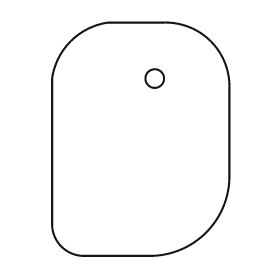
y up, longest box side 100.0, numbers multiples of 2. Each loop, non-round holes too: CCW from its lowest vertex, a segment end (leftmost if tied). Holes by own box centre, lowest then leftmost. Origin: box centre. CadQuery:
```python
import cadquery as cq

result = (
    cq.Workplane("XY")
    .moveTo(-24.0, -50.0)
    .lineTo(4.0, -50.0)
    .threePointArc((28.0, -40.0), (38.0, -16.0))
    .lineTo(38.0, 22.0)
    .threePointArc((30.0, 42.0), (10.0, 50.0))
    .lineTo(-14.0, 50.0)
    .threePointArc((-30.0, 42.0), (-38.0, 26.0))
    .lineTo(-38.0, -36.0)
    .threePointArc((-34.0, -46.0), (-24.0, -50.0))
    .close()
    .moveTo(6.0, 26.0)
    .circle(4.0)
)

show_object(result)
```